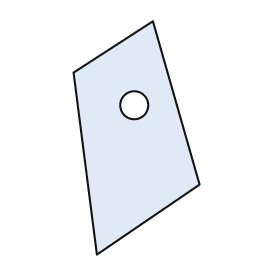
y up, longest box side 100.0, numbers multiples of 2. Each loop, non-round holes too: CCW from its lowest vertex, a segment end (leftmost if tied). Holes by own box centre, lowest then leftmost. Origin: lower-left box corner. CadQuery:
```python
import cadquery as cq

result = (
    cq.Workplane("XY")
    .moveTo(10.0, 0.0)
    .lineTo(54.0, 30.0)
    .lineTo(34.0, 100.0)
    .lineTo(0.0, 78.0)
    .close()
    .moveTo(26.0, 64.0)
    .circle(6.0)
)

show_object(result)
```